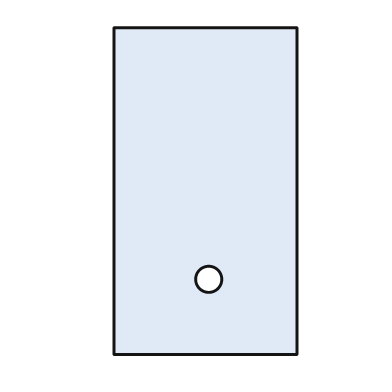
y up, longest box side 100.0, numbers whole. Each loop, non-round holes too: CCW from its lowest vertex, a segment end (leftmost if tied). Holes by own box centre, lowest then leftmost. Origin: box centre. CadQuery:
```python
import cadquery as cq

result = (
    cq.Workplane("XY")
    .moveTo(-28.0, -50.0)
    .lineTo(28.0, -50.0)
    .lineTo(28.0, 50.0)
    .lineTo(-28.0, 50.0)
    .close()
    .moveTo(1.0, -27.0)
    .circle(4.0)
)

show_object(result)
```